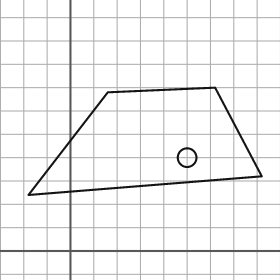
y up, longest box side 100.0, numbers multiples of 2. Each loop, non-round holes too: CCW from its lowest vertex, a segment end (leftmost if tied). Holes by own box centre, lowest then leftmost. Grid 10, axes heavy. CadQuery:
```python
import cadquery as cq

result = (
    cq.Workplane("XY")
    .moveTo(-18.0, 24.0)
    .lineTo(82.0, 32.0)
    .lineTo(62.0, 70.0)
    .lineTo(16.0, 68.0)
    .close()
    .moveTo(50.0, 40.0)
    .circle(4.0)
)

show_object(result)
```